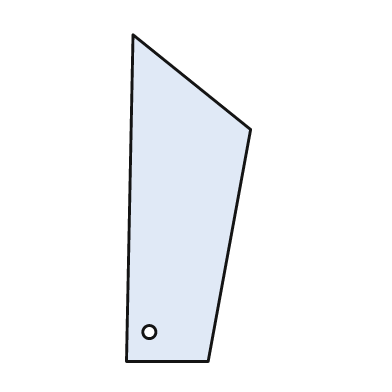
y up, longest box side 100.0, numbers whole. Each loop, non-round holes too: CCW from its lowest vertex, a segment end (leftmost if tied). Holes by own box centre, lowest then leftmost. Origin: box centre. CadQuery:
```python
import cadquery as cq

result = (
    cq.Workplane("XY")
    .moveTo(-19.0, -50.0)
    .lineTo(6.0, -50.0)
    .lineTo(19.0, 21.0)
    .lineTo(-17.0, 50.0)
    .close()
    .moveTo(-12.0, -41.0)
    .circle(2.0)
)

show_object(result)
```